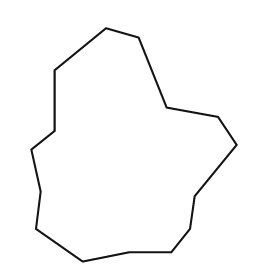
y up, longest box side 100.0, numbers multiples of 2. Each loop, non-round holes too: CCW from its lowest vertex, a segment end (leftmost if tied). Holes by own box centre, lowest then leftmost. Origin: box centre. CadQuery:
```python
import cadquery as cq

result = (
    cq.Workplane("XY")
    .moveTo(-22.0, -50.0)
    .lineTo(-2.0, -46.0)
    .lineTo(16.0, -46.0)
    .lineTo(24.0, -36.0)
    .lineTo(26.0, -22.0)
    .lineTo(44.0, 0.0)
    .lineTo(36.0, 12.0)
    .lineTo(14.0, 16.0)
    .lineTo(2.0, 46.0)
    .lineTo(-12.0, 50.0)
    .lineTo(-34.0, 32.0)
    .lineTo(-34.0, 6.0)
    .lineTo(-44.0, -2.0)
    .lineTo(-40.0, -20.0)
    .lineTo(-42.0, -36.0)
    .close()
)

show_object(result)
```